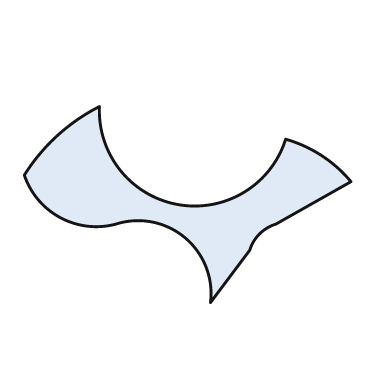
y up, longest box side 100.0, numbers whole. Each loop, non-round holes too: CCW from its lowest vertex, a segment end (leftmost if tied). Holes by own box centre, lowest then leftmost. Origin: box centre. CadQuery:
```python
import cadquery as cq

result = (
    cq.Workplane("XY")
    .moveTo(7.0, -30.0)
    .lineTo(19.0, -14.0)
    .threePointArc((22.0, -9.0), (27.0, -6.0))
    .lineTo(50.0, 7.0)
    .threePointArc((41.0, 15.0), (30.0, 20.0))
    .threePointArc((-3.0, 0.0), (-27.0, 30.0))
    .threePointArc((-40.0, 21.0), (-50.0, 9.0))
    .threePointArc((-39.0, -4.0), (-22.0, -6.0))
    .threePointArc((-1.0, -10.0), (7.0, -30.0))
    .close()
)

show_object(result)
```